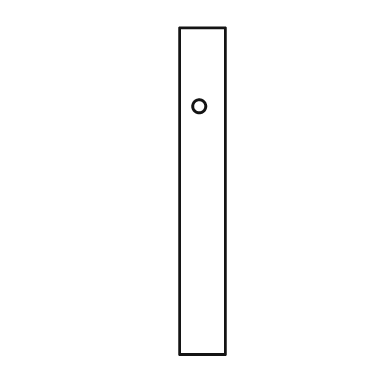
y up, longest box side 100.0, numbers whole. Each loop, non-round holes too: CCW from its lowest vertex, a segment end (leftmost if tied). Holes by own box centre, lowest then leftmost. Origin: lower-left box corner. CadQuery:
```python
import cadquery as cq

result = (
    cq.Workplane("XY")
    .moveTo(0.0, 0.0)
    .lineTo(14.0, 0.0)
    .lineTo(14.0, 100.0)
    .lineTo(0.0, 100.0)
    .close()
    .moveTo(6.0, 76.0)
    .circle(2.0)
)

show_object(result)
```